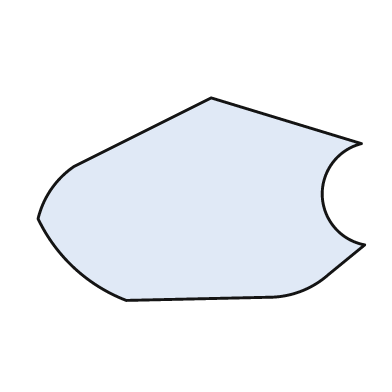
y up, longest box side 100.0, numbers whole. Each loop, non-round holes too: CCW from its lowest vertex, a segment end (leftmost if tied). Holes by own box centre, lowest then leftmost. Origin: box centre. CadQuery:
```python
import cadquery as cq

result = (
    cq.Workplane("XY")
    .moveTo(-23.0, -31.0)
    .lineTo(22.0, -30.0)
    .threePointArc((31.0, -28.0), (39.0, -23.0))
    .lineTo(50.0, -14.0)
    .threePointArc((37.0, 1.0), (49.0, 17.0))
    .lineTo(3.0, 31.0)
    .lineTo(-39.0, 10.0)
    .threePointArc((-46.0, 3.0), (-50.0, -6.0))
    .threePointArc((-39.0, -21.0), (-23.0, -31.0))
    .close()
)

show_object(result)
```